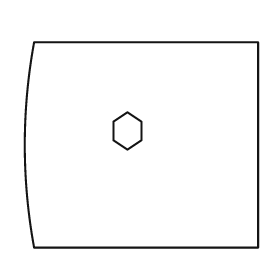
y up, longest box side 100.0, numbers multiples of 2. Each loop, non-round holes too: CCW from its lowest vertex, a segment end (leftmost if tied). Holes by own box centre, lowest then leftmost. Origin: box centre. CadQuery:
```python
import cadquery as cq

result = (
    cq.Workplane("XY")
    .moveTo(-46.0, -44.0)
    .lineTo(50.0, -44.0)
    .lineTo(50.0, 44.0)
    .lineTo(-46.0, 44.0)
    .threePointArc((-50.0, 0.0), (-46.0, -44.0))
    .close()
    .moveTo(-6.0, -2.0)
    .lineTo(0.0, 2.0)
    .lineTo(0.0, 10.0)
    .lineTo(-6.0, 14.0)
    .lineTo(-12.0, 10.0)
    .lineTo(-12.0, 2.0)
    .close()
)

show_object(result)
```